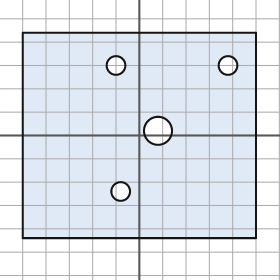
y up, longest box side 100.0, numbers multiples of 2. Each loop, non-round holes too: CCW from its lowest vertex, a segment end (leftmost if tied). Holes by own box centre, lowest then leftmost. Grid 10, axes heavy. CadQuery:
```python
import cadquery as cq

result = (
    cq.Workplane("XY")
    .moveTo(-50.0, -44.0)
    .lineTo(50.0, -44.0)
    .lineTo(50.0, 44.0)
    .lineTo(-50.0, 44.0)
    .close()
    .moveTo(-8.0, -24.0)
    .circle(4.0)
    .moveTo(8.0, 2.0)
    .circle(6.0)
    .moveTo(-10.0, 30.0)
    .circle(4.0)
    .moveTo(38.0, 30.0)
    .circle(4.0)
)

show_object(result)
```